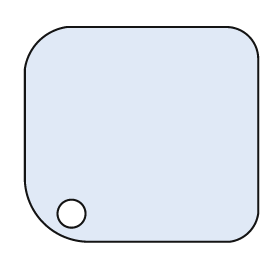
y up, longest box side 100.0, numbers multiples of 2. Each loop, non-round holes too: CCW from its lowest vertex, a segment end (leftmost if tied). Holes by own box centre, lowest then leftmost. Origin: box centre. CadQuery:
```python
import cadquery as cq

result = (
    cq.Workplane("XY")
    .moveTo(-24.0, -46.0)
    .lineTo(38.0, -46.0)
    .threePointArc((46.0, -42.0), (50.0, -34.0))
    .lineTo(50.0, 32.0)
    .threePointArc((46.0, 42.0), (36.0, 46.0))
    .lineTo(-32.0, 46.0)
    .threePointArc((-44.0, 40.0), (-50.0, 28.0))
    .lineTo(-50.0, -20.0)
    .threePointArc((-42.0, -38.0), (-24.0, -46.0))
    .close()
    .moveTo(-30.0, -34.0)
    .circle(6.0)
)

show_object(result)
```